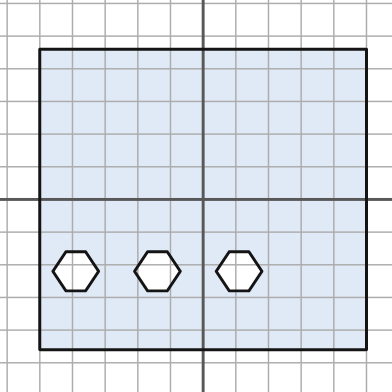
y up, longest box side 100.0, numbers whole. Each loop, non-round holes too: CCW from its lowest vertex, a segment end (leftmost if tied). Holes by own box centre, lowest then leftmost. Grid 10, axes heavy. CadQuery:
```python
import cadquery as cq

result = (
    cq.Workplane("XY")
    .moveTo(-50.0, -46.0)
    .lineTo(50.0, -46.0)
    .lineTo(50.0, 46.0)
    .lineTo(-50.0, 46.0)
    .close()
    .moveTo(-42.0, -28.0)
    .lineTo(-36.0, -28.0)
    .lineTo(-32.0, -22.0)
    .lineTo(-36.0, -16.0)
    .lineTo(-42.0, -16.0)
    .lineTo(-46.0, -22.0)
    .close()
    .moveTo(-17.0, -28.0)
    .lineTo(-11.0, -28.0)
    .lineTo(-7.0, -22.0)
    .lineTo(-11.0, -16.0)
    .lineTo(-17.0, -16.0)
    .lineTo(-21.0, -22.0)
    .close()
    .moveTo(8.0, -28.0)
    .lineTo(14.0, -28.0)
    .lineTo(18.0, -22.0)
    .lineTo(14.0, -16.0)
    .lineTo(8.0, -16.0)
    .lineTo(4.0, -22.0)
    .close()
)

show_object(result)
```